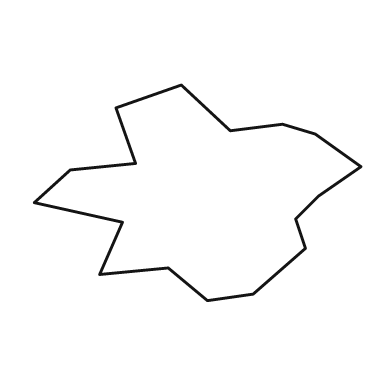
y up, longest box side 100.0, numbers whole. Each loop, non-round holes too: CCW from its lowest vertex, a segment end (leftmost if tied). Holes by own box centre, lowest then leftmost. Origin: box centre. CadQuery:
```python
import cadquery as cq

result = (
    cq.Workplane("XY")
    .moveTo(3.0, -33.0)
    .lineTo(17.0, -31.0)
    .lineTo(33.0, -17.0)
    .lineTo(30.0, -8.0)
    .lineTo(37.0, -1.0)
    .lineTo(50.0, 8.0)
    .lineTo(36.0, 18.0)
    .lineTo(26.0, 21.0)
    .lineTo(10.0, 19.0)
    .lineTo(-5.0, 33.0)
    .lineTo(-25.0, 26.0)
    .lineTo(-19.0, 9.0)
    .lineTo(-39.0, 7.0)
    .lineTo(-50.0, -3.0)
    .lineTo(-23.0, -9.0)
    .lineTo(-30.0, -25.0)
    .lineTo(-9.0, -23.0)
    .close()
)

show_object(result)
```